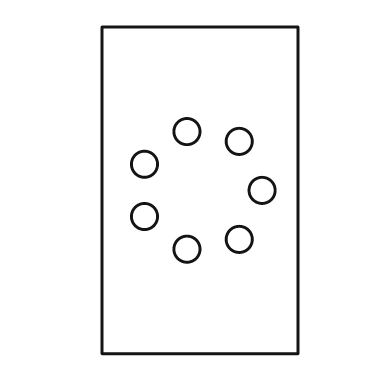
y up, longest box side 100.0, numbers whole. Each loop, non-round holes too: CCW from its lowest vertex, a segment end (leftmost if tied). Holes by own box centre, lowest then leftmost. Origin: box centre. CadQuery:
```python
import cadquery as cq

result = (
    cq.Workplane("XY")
    .moveTo(-30.0, -50.0)
    .lineTo(30.0, -50.0)
    .lineTo(30.0, 50.0)
    .lineTo(-30.0, 50.0)
    .close()
    .moveTo(-4.0, -18.0)
    .circle(4.0)
    .moveTo(12.0, -15.0)
    .circle(4.0)
    .moveTo(-17.0, -8.0)
    .circle(4.0)
    .moveTo(19.0, 0.0)
    .circle(4.0)
    .moveTo(-17.0, 8.0)
    .circle(4.0)
    .moveTo(12.0, 15.0)
    .circle(4.0)
    .moveTo(-4.0, 18.0)
    .circle(4.0)
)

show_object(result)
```